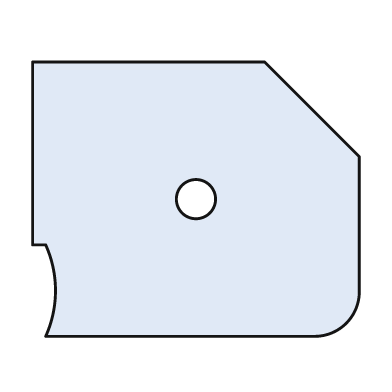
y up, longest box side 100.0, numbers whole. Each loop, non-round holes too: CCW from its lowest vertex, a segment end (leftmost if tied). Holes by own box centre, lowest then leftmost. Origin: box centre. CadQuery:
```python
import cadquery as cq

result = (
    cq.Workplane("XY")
    .moveTo(-46.0, -42.0)
    .lineTo(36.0, -42.0)
    .threePointArc((46.0, -38.0), (50.0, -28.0))
    .lineTo(50.0, 13.0)
    .lineTo(21.0, 42.0)
    .lineTo(-50.0, 42.0)
    .lineTo(-50.0, -14.0)
    .lineTo(-46.0, -14.0)
    .threePointArc((-43.0, -28.0), (-46.0, -42.0))
    .close()
    .moveTo(0.0, 0.0)
    .circle(6.0)
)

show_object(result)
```